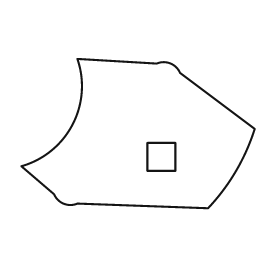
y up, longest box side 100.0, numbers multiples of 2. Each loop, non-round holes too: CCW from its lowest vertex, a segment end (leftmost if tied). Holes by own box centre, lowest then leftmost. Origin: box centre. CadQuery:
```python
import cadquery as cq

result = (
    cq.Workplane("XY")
    .moveTo(30.0, -32.0)
    .threePointArc((42.0, -16.0), (50.0, 2.0))
    .lineTo(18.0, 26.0)
    .threePointArc((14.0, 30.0), (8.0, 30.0))
    .lineTo(-26.0, 32.0)
    .threePointArc((-28.0, 4.0), (-50.0, -14.0))
    .lineTo(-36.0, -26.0)
    .threePointArc((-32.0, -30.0), (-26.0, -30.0))
    .close()
    .moveTo(4.0, -16.0)
    .lineTo(16.0, -16.0)
    .lineTo(16.0, -4.0)
    .lineTo(4.0, -4.0)
    .close()
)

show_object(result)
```